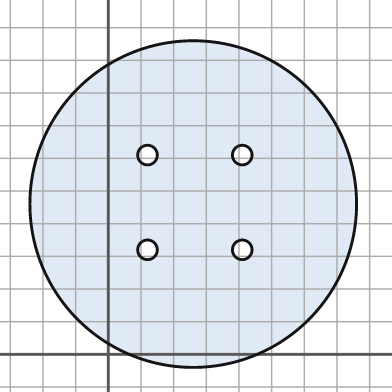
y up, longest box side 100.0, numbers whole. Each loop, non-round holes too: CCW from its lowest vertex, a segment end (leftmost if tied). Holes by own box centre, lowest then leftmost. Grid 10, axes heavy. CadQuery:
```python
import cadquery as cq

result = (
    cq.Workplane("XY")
    .moveTo(26.0, 46.0)
    .circle(50.0)
    .moveTo(12.0, 32.0)
    .circle(3.0)
    .moveTo(41.0, 32.0)
    .circle(3.0)
    .moveTo(12.0, 61.0)
    .circle(3.0)
    .moveTo(41.0, 61.0)
    .circle(3.0)
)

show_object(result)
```